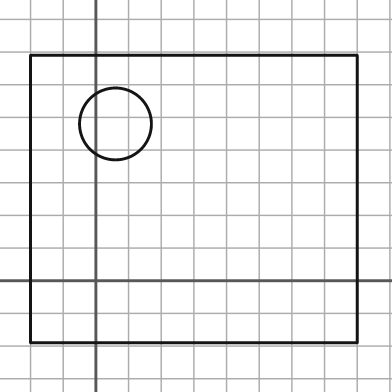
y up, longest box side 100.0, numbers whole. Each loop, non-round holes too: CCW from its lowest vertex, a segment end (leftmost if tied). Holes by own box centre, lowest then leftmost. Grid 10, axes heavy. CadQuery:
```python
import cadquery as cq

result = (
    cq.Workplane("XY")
    .moveTo(-20.0, -19.0)
    .lineTo(80.0, -19.0)
    .lineTo(80.0, 69.0)
    .lineTo(-20.0, 69.0)
    .close()
    .moveTo(6.0, 48.0)
    .circle(11.0)
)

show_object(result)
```